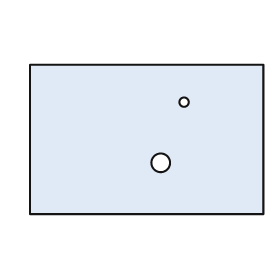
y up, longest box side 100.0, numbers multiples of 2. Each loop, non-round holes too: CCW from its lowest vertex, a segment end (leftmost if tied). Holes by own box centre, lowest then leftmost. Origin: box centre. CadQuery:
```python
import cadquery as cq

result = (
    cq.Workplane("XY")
    .moveTo(-50.0, -32.0)
    .lineTo(50.0, -32.0)
    .lineTo(50.0, 32.0)
    .lineTo(-50.0, 32.0)
    .close()
    .moveTo(6.0, -10.0)
    .circle(4.0)
    .moveTo(16.0, 16.0)
    .circle(2.0)
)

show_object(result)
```